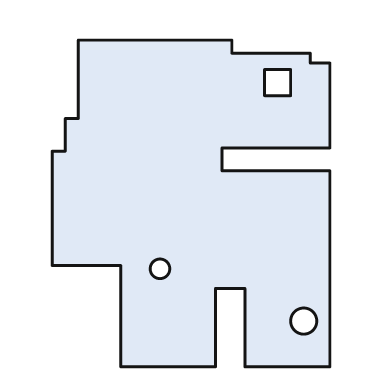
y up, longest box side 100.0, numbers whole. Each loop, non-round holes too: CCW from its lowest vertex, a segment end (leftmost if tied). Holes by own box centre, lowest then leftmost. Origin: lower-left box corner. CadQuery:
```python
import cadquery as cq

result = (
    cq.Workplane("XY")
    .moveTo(21.0, 0.0)
    .lineTo(50.0, 0.0)
    .lineTo(50.0, 24.0)
    .lineTo(59.0, 24.0)
    .lineTo(59.0, 0.0)
    .lineTo(85.0, 0.0)
    .lineTo(85.0, 60.0)
    .lineTo(52.0, 60.0)
    .lineTo(52.0, 67.0)
    .lineTo(85.0, 67.0)
    .lineTo(85.0, 93.0)
    .lineTo(79.0, 93.0)
    .lineTo(79.0, 96.0)
    .lineTo(55.0, 96.0)
    .lineTo(55.0, 100.0)
    .lineTo(8.0, 100.0)
    .lineTo(8.0, 76.0)
    .lineTo(4.0, 76.0)
    .lineTo(4.0, 66.0)
    .lineTo(0.0, 66.0)
    .lineTo(0.0, 31.0)
    .lineTo(21.0, 31.0)
    .close()
    .moveTo(77.0, 14.0)
    .circle(4.0)
    .moveTo(33.0, 30.0)
    .circle(3.0)
    .moveTo(65.0, 83.0)
    .lineTo(73.0, 83.0)
    .lineTo(73.0, 91.0)
    .lineTo(65.0, 91.0)
    .close()
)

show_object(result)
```